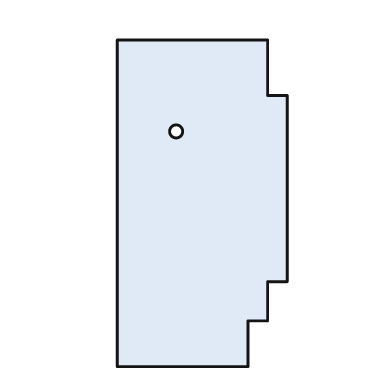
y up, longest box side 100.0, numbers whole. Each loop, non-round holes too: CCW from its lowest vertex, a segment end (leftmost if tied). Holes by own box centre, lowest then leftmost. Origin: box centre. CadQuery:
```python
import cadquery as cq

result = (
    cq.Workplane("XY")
    .moveTo(-26.0, -50.0)
    .lineTo(14.0, -50.0)
    .lineTo(14.0, -36.0)
    .lineTo(20.0, -36.0)
    .lineTo(20.0, -24.0)
    .lineTo(26.0, -24.0)
    .lineTo(26.0, 33.0)
    .lineTo(20.0, 33.0)
    .lineTo(20.0, 50.0)
    .lineTo(-26.0, 50.0)
    .close()
    .moveTo(-8.0, 22.0)
    .circle(2.0)
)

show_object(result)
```